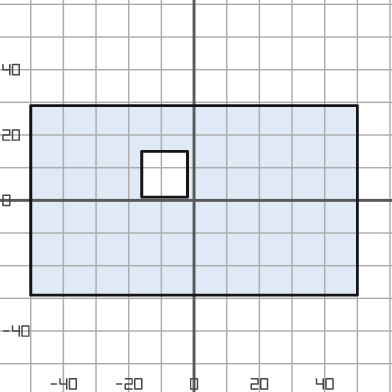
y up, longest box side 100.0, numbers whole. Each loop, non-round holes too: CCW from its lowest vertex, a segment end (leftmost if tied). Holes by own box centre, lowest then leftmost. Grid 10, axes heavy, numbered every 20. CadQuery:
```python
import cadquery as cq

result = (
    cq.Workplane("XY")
    .moveTo(-50.0, -29.0)
    .lineTo(50.0, -29.0)
    .lineTo(50.0, 29.0)
    .lineTo(-50.0, 29.0)
    .close()
    .moveTo(-16.0, 1.0)
    .lineTo(-2.0, 1.0)
    .lineTo(-2.0, 15.0)
    .lineTo(-16.0, 15.0)
    .close()
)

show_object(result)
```